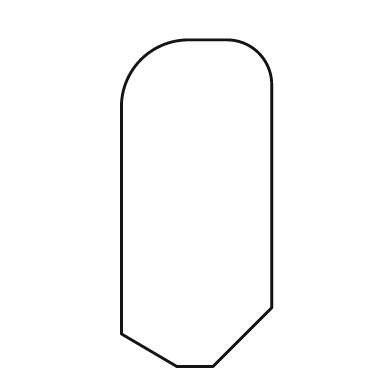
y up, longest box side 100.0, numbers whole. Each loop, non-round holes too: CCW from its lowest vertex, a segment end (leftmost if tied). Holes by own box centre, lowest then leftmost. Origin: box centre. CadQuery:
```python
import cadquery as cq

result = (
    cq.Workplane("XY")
    .moveTo(-6.0, -50.0)
    .lineTo(5.0, -50.0)
    .lineTo(23.0, -32.0)
    .lineTo(23.0, 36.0)
    .threePointArc((19.0, 46.0), (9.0, 50.0))
    .lineTo(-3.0, 50.0)
    .threePointArc((-17.0, 44.0), (-23.0, 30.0))
    .lineTo(-23.0, -40.0)
    .close()
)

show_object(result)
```